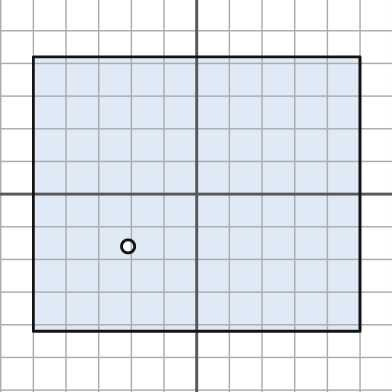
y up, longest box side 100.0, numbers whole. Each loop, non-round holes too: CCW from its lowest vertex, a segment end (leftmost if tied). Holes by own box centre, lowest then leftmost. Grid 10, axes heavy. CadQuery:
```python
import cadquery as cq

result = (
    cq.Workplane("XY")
    .moveTo(-50.0, -42.0)
    .lineTo(50.0, -42.0)
    .lineTo(50.0, 42.0)
    .lineTo(-50.0, 42.0)
    .close()
    .moveTo(-21.0, -16.0)
    .circle(2.0)
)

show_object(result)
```